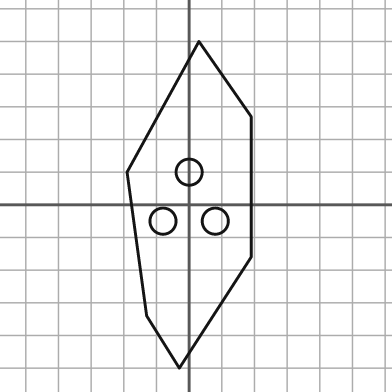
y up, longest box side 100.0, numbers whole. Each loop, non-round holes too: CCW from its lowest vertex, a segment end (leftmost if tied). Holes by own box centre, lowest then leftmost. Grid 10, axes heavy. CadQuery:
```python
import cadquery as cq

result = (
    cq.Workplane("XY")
    .moveTo(-3.0, -50.0)
    .lineTo(19.0, -16.0)
    .lineTo(19.0, 27.0)
    .lineTo(3.0, 50.0)
    .lineTo(-19.0, 10.0)
    .lineTo(-13.0, -34.0)
    .close()
    .moveTo(-8.0, -5.0)
    .circle(4.0)
    .moveTo(8.0, -5.0)
    .circle(4.0)
    .moveTo(0.0, 10.0)
    .circle(4.0)
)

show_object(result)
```